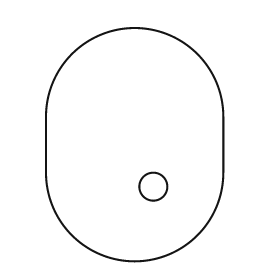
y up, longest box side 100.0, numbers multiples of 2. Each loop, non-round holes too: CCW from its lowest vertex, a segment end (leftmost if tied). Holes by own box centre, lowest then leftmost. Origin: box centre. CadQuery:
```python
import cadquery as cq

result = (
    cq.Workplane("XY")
    .moveTo(-38.0, -12.0)
    .threePointArc((0.0, -50.0), (38.0, -12.0))
    .lineTo(38.0, 12.0)
    .threePointArc((0.0, 50.0), (-38.0, 12.0))
    .close()
    .moveTo(8.0, -18.0)
    .circle(6.0)
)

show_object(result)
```